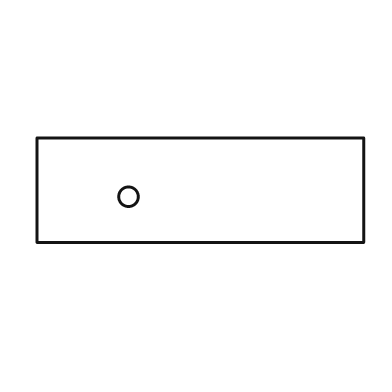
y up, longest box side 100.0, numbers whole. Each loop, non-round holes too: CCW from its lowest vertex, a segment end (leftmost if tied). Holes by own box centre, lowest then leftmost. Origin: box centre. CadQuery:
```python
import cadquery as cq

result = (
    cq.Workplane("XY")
    .moveTo(-50.0, -16.0)
    .lineTo(50.0, -16.0)
    .lineTo(50.0, 16.0)
    .lineTo(-50.0, 16.0)
    .close()
    .moveTo(-22.0, -2.0)
    .circle(3.0)
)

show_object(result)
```